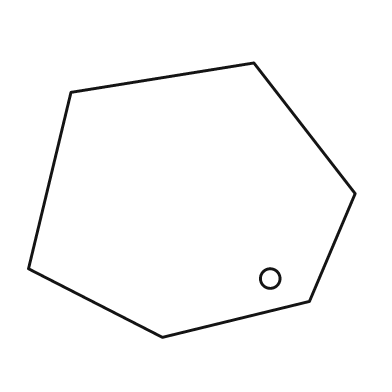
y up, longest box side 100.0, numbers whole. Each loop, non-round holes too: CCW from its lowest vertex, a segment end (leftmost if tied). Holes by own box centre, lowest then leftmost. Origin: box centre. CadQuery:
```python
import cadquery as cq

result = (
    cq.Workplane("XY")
    .moveTo(-9.0, -42.0)
    .lineTo(36.0, -31.0)
    .lineTo(50.0, 2.0)
    .lineTo(19.0, 42.0)
    .lineTo(-37.0, 33.0)
    .lineTo(-50.0, -21.0)
    .close()
    .moveTo(24.0, -24.0)
    .circle(3.0)
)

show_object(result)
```